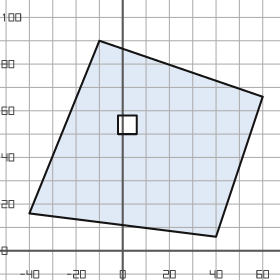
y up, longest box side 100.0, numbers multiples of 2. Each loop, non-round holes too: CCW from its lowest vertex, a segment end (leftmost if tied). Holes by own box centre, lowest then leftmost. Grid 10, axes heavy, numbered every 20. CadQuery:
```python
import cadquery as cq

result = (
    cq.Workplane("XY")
    .moveTo(40.0, 6.0)
    .lineTo(60.0, 66.0)
    .lineTo(-10.0, 90.0)
    .lineTo(-40.0, 16.0)
    .close()
    .moveTo(-2.0, 50.0)
    .lineTo(6.0, 50.0)
    .lineTo(6.0, 58.0)
    .lineTo(-2.0, 58.0)
    .close()
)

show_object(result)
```